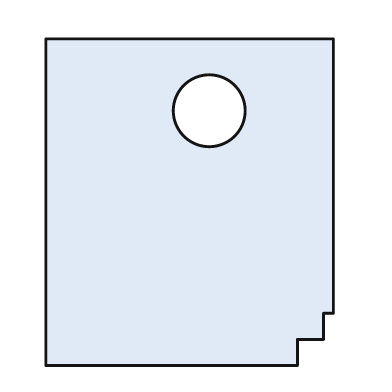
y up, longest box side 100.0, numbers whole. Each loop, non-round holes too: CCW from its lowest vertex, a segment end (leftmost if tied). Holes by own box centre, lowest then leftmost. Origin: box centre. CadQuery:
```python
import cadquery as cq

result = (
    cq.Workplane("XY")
    .moveTo(-44.0, -50.0)
    .lineTo(33.0, -50.0)
    .lineTo(33.0, -42.0)
    .lineTo(41.0, -42.0)
    .lineTo(41.0, -34.0)
    .lineTo(44.0, -34.0)
    .lineTo(44.0, 50.0)
    .lineTo(-44.0, 50.0)
    .close()
    .moveTo(6.0, 28.0)
    .circle(11.0)
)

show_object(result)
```